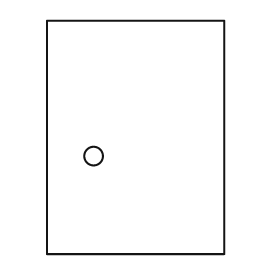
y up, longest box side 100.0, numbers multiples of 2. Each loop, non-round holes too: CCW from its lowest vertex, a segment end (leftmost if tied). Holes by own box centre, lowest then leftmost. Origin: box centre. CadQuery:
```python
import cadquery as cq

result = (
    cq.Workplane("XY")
    .moveTo(-38.0, -50.0)
    .lineTo(38.0, -50.0)
    .lineTo(38.0, 50.0)
    .lineTo(-38.0, 50.0)
    .close()
    .moveTo(-18.0, -8.0)
    .circle(4.0)
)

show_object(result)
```